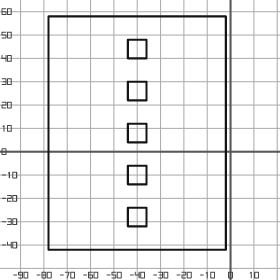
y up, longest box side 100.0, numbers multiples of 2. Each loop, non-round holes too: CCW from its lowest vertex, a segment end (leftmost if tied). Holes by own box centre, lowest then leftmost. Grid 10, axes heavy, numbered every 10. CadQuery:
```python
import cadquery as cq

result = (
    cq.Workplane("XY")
    .moveTo(-78.0, -42.0)
    .lineTo(-2.0, -42.0)
    .lineTo(-2.0, 58.0)
    .lineTo(-78.0, 58.0)
    .close()
    .moveTo(-44.0, -32.0)
    .lineTo(-36.0, -32.0)
    .lineTo(-36.0, -24.0)
    .lineTo(-44.0, -24.0)
    .close()
    .moveTo(-44.0, -14.0)
    .lineTo(-36.0, -14.0)
    .lineTo(-36.0, -6.0)
    .lineTo(-44.0, -6.0)
    .close()
    .moveTo(-44.0, 4.0)
    .lineTo(-36.0, 4.0)
    .lineTo(-36.0, 12.0)
    .lineTo(-44.0, 12.0)
    .close()
    .moveTo(-44.0, 22.0)
    .lineTo(-36.0, 22.0)
    .lineTo(-36.0, 30.0)
    .lineTo(-44.0, 30.0)
    .close()
    .moveTo(-44.0, 40.0)
    .lineTo(-36.0, 40.0)
    .lineTo(-36.0, 48.0)
    .lineTo(-44.0, 48.0)
    .close()
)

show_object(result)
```